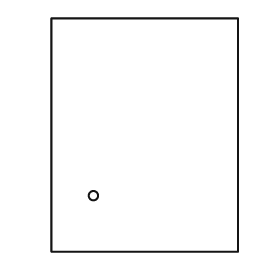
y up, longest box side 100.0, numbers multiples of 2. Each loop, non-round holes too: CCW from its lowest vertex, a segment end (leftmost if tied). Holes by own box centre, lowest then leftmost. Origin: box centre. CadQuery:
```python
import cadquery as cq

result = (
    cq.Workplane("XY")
    .moveTo(-40.0, -50.0)
    .lineTo(40.0, -50.0)
    .lineTo(40.0, 50.0)
    .lineTo(-40.0, 50.0)
    .close()
    .moveTo(-22.0, -26.0)
    .circle(2.0)
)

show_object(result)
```